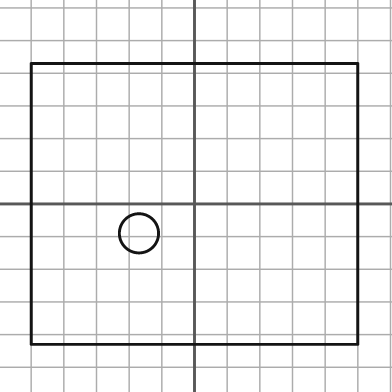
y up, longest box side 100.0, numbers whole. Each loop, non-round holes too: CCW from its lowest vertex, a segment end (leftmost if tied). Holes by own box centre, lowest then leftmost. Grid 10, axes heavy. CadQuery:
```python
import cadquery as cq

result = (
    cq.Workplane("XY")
    .moveTo(-50.0, -43.0)
    .lineTo(50.0, -43.0)
    .lineTo(50.0, 43.0)
    .lineTo(-50.0, 43.0)
    .close()
    .moveTo(-17.0, -9.0)
    .circle(6.0)
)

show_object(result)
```